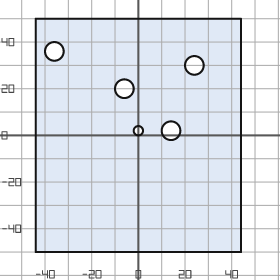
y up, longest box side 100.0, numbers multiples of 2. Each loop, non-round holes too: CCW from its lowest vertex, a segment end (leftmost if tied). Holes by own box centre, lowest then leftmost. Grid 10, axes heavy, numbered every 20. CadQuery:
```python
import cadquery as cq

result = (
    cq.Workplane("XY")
    .moveTo(-44.0, -50.0)
    .lineTo(44.0, -50.0)
    .lineTo(44.0, 50.0)
    .lineTo(-44.0, 50.0)
    .close()
    .moveTo(0.0, 2.0)
    .circle(2.0)
    .moveTo(14.0, 2.0)
    .circle(4.0)
    .moveTo(-6.0, 20.0)
    .circle(4.0)
    .moveTo(24.0, 30.0)
    .circle(4.0)
    .moveTo(-36.0, 36.0)
    .circle(4.0)
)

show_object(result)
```